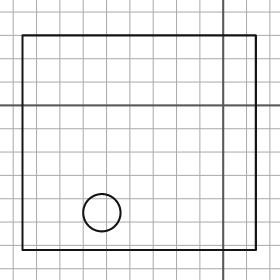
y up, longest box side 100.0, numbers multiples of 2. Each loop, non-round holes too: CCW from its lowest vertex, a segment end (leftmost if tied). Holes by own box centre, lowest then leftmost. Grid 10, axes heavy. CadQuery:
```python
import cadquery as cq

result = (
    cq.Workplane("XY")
    .moveTo(-86.0, -62.0)
    .lineTo(14.0, -62.0)
    .lineTo(14.0, 30.0)
    .lineTo(-86.0, 30.0)
    .close()
    .moveTo(-52.0, -46.0)
    .circle(8.0)
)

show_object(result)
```